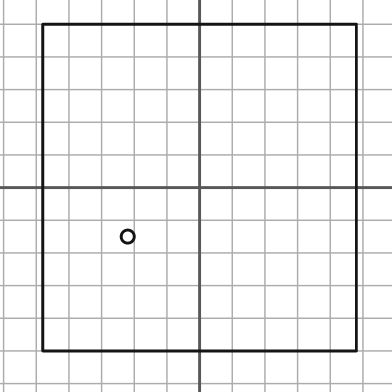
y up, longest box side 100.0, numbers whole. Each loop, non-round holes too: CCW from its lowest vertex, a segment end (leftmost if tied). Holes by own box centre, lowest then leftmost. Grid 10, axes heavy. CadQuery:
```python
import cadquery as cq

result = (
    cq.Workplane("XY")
    .moveTo(-48.0, -50.0)
    .lineTo(48.0, -50.0)
    .lineTo(48.0, 50.0)
    .lineTo(-48.0, 50.0)
    .close()
    .moveTo(-22.0, -15.0)
    .circle(2.0)
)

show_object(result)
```